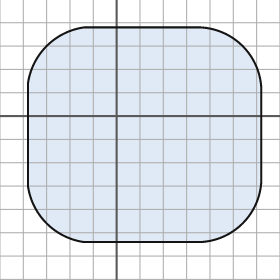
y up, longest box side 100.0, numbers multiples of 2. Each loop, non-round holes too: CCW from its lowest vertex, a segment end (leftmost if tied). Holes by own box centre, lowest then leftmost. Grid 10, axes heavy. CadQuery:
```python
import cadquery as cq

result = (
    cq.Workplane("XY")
    .moveTo(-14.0, -54.0)
    .lineTo(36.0, -54.0)
    .threePointArc((54.0, -46.0), (62.0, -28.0))
    .lineTo(62.0, 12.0)
    .threePointArc((54.0, 30.0), (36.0, 38.0))
    .lineTo(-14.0, 38.0)
    .threePointArc((-30.0, 30.0), (-38.0, 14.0))
    .lineTo(-38.0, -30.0)
    .threePointArc((-30.0, -46.0), (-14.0, -54.0))
    .close()
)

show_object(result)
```